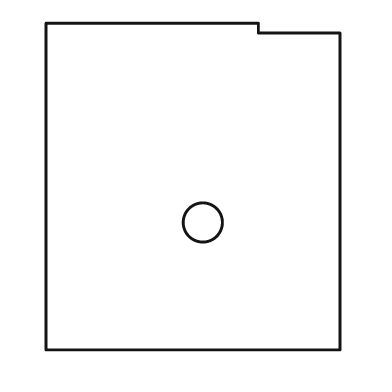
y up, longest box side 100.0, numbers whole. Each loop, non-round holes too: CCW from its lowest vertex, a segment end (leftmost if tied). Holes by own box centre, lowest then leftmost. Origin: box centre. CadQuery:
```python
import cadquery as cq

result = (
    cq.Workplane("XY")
    .moveTo(-45.0, -50.0)
    .lineTo(45.0, -50.0)
    .lineTo(45.0, 47.0)
    .lineTo(20.0, 47.0)
    .lineTo(20.0, 50.0)
    .lineTo(-45.0, 50.0)
    .close()
    .moveTo(3.0, -11.0)
    .circle(6.0)
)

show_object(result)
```